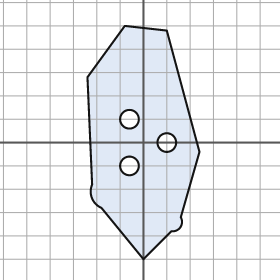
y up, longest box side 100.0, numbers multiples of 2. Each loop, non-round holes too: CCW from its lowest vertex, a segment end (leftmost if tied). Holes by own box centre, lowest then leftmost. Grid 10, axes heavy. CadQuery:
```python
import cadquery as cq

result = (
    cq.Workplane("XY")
    .moveTo(0.0, -50.0)
    .lineTo(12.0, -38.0)
    .threePointArc((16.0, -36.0), (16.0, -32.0))
    .lineTo(24.0, -4.0)
    .lineTo(10.0, 48.0)
    .lineTo(-8.0, 50.0)
    .lineTo(-24.0, 28.0)
    .lineTo(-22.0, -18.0)
    .threePointArc((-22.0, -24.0), (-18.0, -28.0))
    .close()
    .moveTo(-6.0, -10.0)
    .circle(4.0)
    .moveTo(10.0, 0.0)
    .circle(4.0)
    .moveTo(-6.0, 10.0)
    .circle(4.0)
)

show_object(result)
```